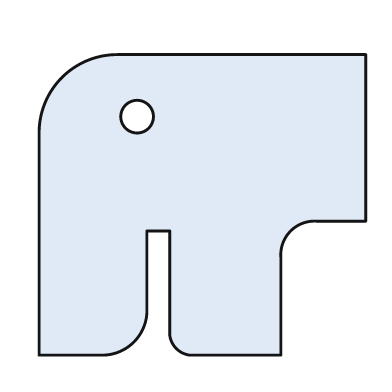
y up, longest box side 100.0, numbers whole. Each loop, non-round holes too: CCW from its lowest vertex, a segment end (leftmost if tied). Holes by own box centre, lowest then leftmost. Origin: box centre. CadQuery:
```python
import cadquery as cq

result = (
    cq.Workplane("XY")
    .moveTo(-50.0, -46.0)
    .lineTo(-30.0, -46.0)
    .threePointArc((-21.0, -42.0), (-17.0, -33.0))
    .lineTo(-17.0, -8.0)
    .lineTo(-10.0, -8.0)
    .lineTo(-10.0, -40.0)
    .threePointArc((-8.0, -44.0), (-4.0, -46.0))
    .lineTo(24.0, -46.0)
    .lineTo(24.0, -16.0)
    .threePointArc((27.0, -8.0), (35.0, -5.0))
    .lineTo(50.0, -5.0)
    .lineTo(50.0, 46.0)
    .lineTo(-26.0, 46.0)
    .threePointArc((-43.0, 39.0), (-50.0, 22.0))
    .close()
    .moveTo(-20.0, 27.0)
    .circle(5.0)
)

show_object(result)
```